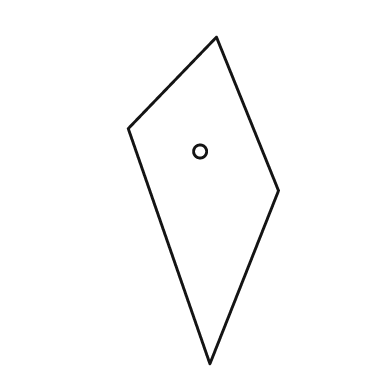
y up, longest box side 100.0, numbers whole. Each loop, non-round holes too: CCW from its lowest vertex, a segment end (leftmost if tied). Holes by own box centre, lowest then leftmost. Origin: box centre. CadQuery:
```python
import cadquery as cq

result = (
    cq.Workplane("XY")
    .moveTo(2.0, -50.0)
    .lineTo(23.0, 3.0)
    .lineTo(4.0, 50.0)
    .lineTo(-23.0, 22.0)
    .close()
    .moveTo(-1.0, 15.0)
    .circle(2.0)
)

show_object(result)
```